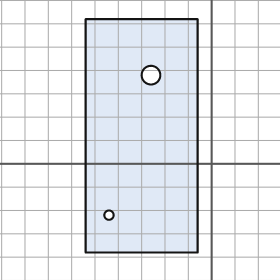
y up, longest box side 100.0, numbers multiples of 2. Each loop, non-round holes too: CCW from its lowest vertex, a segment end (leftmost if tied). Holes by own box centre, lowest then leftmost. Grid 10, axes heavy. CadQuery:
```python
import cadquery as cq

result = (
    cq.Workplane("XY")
    .moveTo(-54.0, -38.0)
    .lineTo(-6.0, -38.0)
    .lineTo(-6.0, 62.0)
    .lineTo(-54.0, 62.0)
    .close()
    .moveTo(-44.0, -22.0)
    .circle(2.0)
    .moveTo(-26.0, 38.0)
    .circle(4.0)
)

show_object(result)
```